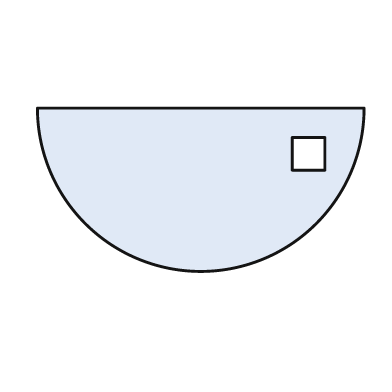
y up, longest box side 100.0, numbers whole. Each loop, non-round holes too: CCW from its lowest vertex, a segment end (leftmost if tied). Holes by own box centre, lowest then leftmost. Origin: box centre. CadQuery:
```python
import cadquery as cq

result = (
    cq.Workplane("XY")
    .moveTo(-50.0, 25.0)
    .threePointArc((0.0, -25.0), (50.0, 25.0))
    .close()
    .moveTo(28.0, 6.0)
    .lineTo(38.0, 6.0)
    .lineTo(38.0, 16.0)
    .lineTo(28.0, 16.0)
    .close()
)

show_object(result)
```